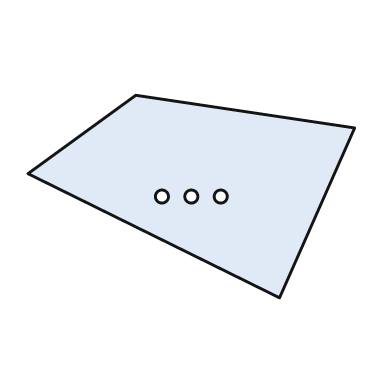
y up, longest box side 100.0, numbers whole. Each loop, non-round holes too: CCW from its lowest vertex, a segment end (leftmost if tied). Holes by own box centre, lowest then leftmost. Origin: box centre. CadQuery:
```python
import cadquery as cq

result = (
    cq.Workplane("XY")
    .moveTo(27.0, -31.0)
    .lineTo(50.0, 21.0)
    .lineTo(-17.0, 31.0)
    .lineTo(-50.0, 7.0)
    .close()
    .moveTo(-9.0, 0.0)
    .circle(2.0)
    .moveTo(0.0, 0.0)
    .circle(2.0)
    .moveTo(9.0, 0.0)
    .circle(2.0)
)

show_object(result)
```